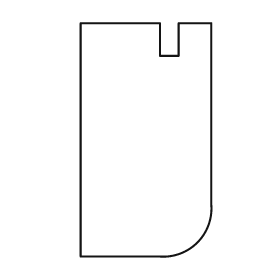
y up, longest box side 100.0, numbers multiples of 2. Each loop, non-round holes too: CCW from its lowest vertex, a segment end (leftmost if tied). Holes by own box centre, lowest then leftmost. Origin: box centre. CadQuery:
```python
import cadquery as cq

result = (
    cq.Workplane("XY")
    .moveTo(-28.0, -50.0)
    .lineTo(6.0, -50.0)
    .threePointArc((22.0, -44.0), (28.0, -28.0))
    .lineTo(28.0, 50.0)
    .lineTo(14.0, 50.0)
    .lineTo(14.0, 36.0)
    .lineTo(6.0, 36.0)
    .lineTo(6.0, 50.0)
    .lineTo(-28.0, 50.0)
    .close()
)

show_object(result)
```